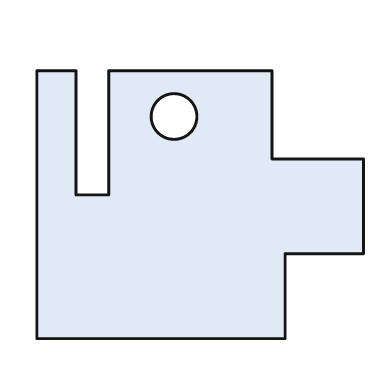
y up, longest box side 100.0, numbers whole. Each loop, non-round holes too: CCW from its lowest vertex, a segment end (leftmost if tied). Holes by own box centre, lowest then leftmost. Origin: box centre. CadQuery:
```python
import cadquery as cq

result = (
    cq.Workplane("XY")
    .moveTo(-50.0, -41.0)
    .lineTo(26.0, -41.0)
    .lineTo(26.0, -15.0)
    .lineTo(50.0, -15.0)
    .lineTo(50.0, 14.0)
    .lineTo(22.0, 14.0)
    .lineTo(22.0, 41.0)
    .lineTo(-28.0, 41.0)
    .lineTo(-28.0, 3.0)
    .lineTo(-38.0, 3.0)
    .lineTo(-38.0, 41.0)
    .lineTo(-50.0, 41.0)
    .close()
    .moveTo(-8.0, 27.0)
    .circle(7.0)
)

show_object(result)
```